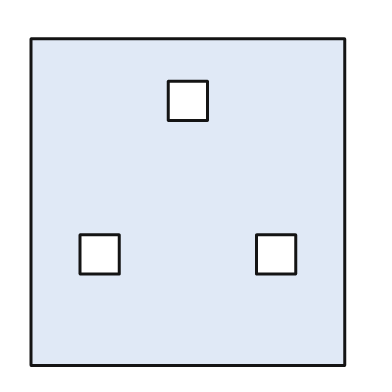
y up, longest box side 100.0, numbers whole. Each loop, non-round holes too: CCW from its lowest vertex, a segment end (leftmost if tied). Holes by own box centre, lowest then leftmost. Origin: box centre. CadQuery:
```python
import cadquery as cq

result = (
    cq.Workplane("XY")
    .moveTo(-48.0, -50.0)
    .lineTo(48.0, -50.0)
    .lineTo(48.0, 50.0)
    .lineTo(-48.0, 50.0)
    .close()
    .moveTo(-33.0, -22.0)
    .lineTo(-21.0, -22.0)
    .lineTo(-21.0, -10.0)
    .lineTo(-33.0, -10.0)
    .close()
    .moveTo(21.0, -22.0)
    .lineTo(33.0, -22.0)
    .lineTo(33.0, -10.0)
    .lineTo(21.0, -10.0)
    .close()
    .moveTo(-6.0, 25.0)
    .lineTo(6.0, 25.0)
    .lineTo(6.0, 37.0)
    .lineTo(-6.0, 37.0)
    .close()
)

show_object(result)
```